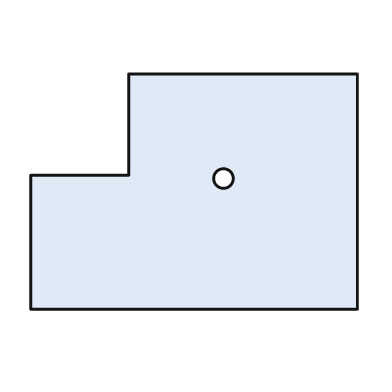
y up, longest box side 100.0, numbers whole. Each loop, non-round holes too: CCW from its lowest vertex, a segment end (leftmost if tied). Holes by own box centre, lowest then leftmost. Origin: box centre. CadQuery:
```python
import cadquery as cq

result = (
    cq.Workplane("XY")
    .moveTo(-50.0, -36.0)
    .lineTo(50.0, -36.0)
    .lineTo(50.0, 36.0)
    .lineTo(-20.0, 36.0)
    .lineTo(-20.0, 5.0)
    .lineTo(-50.0, 5.0)
    .close()
    .moveTo(9.0, 4.0)
    .circle(3.0)
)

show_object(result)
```